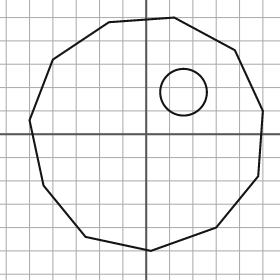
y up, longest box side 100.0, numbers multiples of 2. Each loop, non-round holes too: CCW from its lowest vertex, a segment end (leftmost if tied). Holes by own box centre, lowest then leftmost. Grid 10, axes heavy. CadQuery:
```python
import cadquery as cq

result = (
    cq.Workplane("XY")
    .moveTo(2.0, -50.0)
    .lineTo(30.0, -40.0)
    .lineTo(48.0, -18.0)
    .lineTo(50.0, 10.0)
    .lineTo(38.0, 36.0)
    .lineTo(12.0, 50.0)
    .lineTo(-16.0, 48.0)
    .lineTo(-40.0, 32.0)
    .lineTo(-50.0, 6.0)
    .lineTo(-44.0, -22.0)
    .lineTo(-26.0, -44.0)
    .close()
    .moveTo(16.0, 18.0)
    .circle(10.0)
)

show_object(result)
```